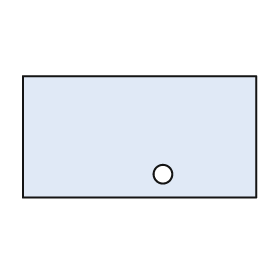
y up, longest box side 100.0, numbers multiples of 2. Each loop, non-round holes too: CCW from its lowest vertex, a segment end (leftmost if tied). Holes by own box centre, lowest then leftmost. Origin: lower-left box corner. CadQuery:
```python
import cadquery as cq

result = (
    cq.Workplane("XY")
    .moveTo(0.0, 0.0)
    .lineTo(100.0, 0.0)
    .lineTo(100.0, 52.0)
    .lineTo(0.0, 52.0)
    .close()
    .moveTo(60.0, 10.0)
    .circle(4.0)
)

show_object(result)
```